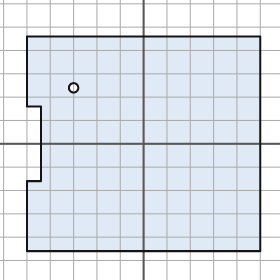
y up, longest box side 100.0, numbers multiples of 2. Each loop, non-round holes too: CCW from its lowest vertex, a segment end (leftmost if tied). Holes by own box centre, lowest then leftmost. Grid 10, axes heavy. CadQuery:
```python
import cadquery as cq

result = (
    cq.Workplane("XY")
    .moveTo(-50.0, -46.0)
    .lineTo(50.0, -46.0)
    .lineTo(50.0, 46.0)
    .lineTo(-50.0, 46.0)
    .lineTo(-50.0, 16.0)
    .lineTo(-44.0, 16.0)
    .lineTo(-44.0, -16.0)
    .lineTo(-50.0, -16.0)
    .close()
    .moveTo(-30.0, 24.0)
    .circle(2.0)
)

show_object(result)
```